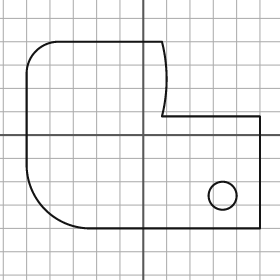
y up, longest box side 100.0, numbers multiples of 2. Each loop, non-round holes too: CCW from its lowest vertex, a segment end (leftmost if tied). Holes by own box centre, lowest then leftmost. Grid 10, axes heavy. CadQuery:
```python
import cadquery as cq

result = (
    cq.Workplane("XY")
    .moveTo(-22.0, -40.0)
    .lineTo(50.0, -40.0)
    .lineTo(50.0, 8.0)
    .lineTo(8.0, 8.0)
    .threePointArc((10.0, 24.0), (8.0, 40.0))
    .lineTo(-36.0, 40.0)
    .threePointArc((-46.0, 36.0), (-50.0, 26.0))
    .lineTo(-50.0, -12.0)
    .threePointArc((-42.0, -32.0), (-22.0, -40.0))
    .close()
    .moveTo(34.0, -26.0)
    .circle(6.0)
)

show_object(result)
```